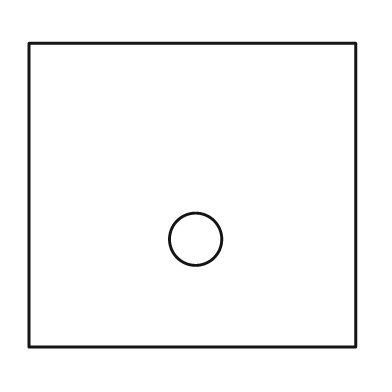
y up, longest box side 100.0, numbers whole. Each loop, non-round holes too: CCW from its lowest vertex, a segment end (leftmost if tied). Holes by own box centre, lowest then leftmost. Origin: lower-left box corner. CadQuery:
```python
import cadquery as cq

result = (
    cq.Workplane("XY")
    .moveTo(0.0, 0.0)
    .lineTo(100.0, 0.0)
    .lineTo(100.0, 93.0)
    .lineTo(0.0, 93.0)
    .close()
    .moveTo(51.0, 33.0)
    .circle(8.0)
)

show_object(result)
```